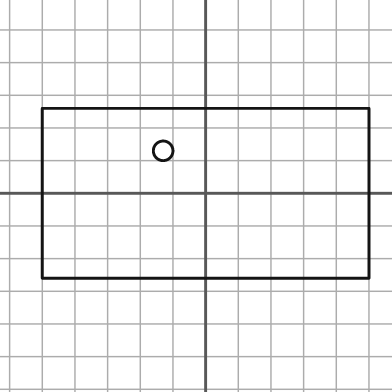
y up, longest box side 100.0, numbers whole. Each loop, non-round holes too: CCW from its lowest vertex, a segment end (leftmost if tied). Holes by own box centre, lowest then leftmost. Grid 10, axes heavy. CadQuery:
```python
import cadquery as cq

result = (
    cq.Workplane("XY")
    .moveTo(-50.0, -26.0)
    .lineTo(50.0, -26.0)
    .lineTo(50.0, 26.0)
    .lineTo(-50.0, 26.0)
    .close()
    .moveTo(-13.0, 13.0)
    .circle(3.0)
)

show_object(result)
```